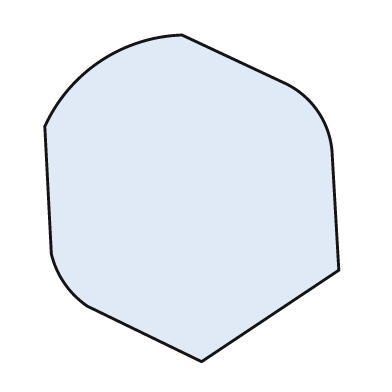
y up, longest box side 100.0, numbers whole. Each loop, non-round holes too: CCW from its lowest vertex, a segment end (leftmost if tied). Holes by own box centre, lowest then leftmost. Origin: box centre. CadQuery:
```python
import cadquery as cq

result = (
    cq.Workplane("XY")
    .moveTo(3.0, -50.0)
    .lineTo(45.0, -22.0)
    .lineTo(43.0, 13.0)
    .threePointArc((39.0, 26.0), (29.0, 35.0))
    .lineTo(-3.0, 50.0)
    .threePointArc((-28.0, 42.0), (-45.0, 22.0))
    .lineTo(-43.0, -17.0)
    .threePointArc((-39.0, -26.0), (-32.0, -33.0))
    .close()
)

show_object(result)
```